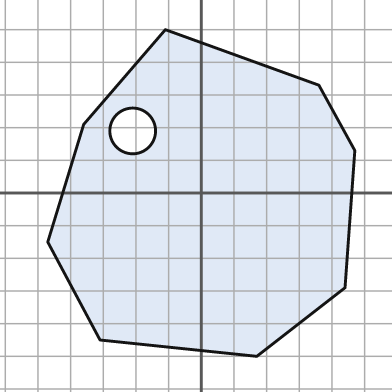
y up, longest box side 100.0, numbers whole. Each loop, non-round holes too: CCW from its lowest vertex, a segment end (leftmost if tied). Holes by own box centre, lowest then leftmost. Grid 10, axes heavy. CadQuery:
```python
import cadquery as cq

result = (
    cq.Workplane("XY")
    .moveTo(17.0, -50.0)
    .lineTo(44.0, -29.0)
    .lineTo(47.0, 13.0)
    .lineTo(36.0, 33.0)
    .lineTo(-11.0, 50.0)
    .lineTo(-36.0, 21.0)
    .lineTo(-47.0, -15.0)
    .lineTo(-31.0, -45.0)
    .close()
    .moveTo(-21.0, 19.0)
    .circle(7.0)
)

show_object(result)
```